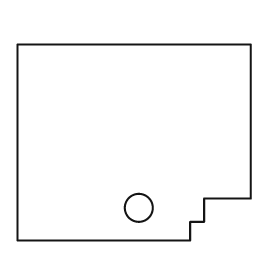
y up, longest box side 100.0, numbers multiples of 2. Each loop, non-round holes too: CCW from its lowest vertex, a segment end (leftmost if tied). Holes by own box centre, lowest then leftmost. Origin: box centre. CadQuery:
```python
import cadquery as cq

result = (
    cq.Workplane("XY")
    .moveTo(-50.0, -42.0)
    .lineTo(24.0, -42.0)
    .lineTo(24.0, -34.0)
    .lineTo(30.0, -34.0)
    .lineTo(30.0, -24.0)
    .lineTo(50.0, -24.0)
    .lineTo(50.0, 42.0)
    .lineTo(-50.0, 42.0)
    .close()
    .moveTo(2.0, -28.0)
    .circle(6.0)
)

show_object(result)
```